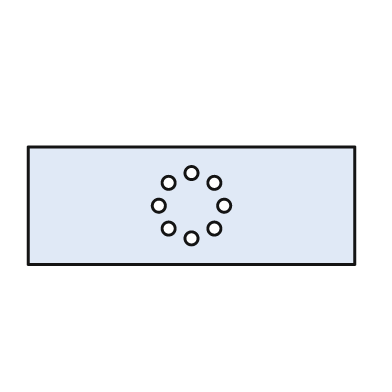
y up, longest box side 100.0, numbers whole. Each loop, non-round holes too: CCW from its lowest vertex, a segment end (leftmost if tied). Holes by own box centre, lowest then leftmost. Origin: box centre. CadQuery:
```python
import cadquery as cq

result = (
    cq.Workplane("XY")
    .moveTo(-50.0, -18.0)
    .lineTo(50.0, -18.0)
    .lineTo(50.0, 18.0)
    .lineTo(-50.0, 18.0)
    .close()
    .moveTo(0.0, -10.0)
    .circle(2.0)
    .moveTo(-7.0, -7.0)
    .circle(2.0)
    .moveTo(7.0, -7.0)
    .circle(2.0)
    .moveTo(-10.0, 0.0)
    .circle(2.0)
    .moveTo(10.0, 0.0)
    .circle(2.0)
    .moveTo(-7.0, 7.0)
    .circle(2.0)
    .moveTo(7.0, 7.0)
    .circle(2.0)
    .moveTo(0.0, 10.0)
    .circle(2.0)
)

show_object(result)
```